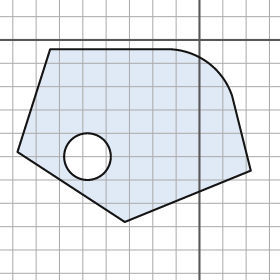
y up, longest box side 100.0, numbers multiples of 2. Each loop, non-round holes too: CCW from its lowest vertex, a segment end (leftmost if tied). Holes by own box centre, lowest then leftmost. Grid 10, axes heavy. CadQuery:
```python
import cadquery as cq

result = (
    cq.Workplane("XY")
    .moveTo(-32.0, -78.0)
    .lineTo(22.0, -56.0)
    .lineTo(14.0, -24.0)
    .threePointArc((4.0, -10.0), (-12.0, -4.0))
    .lineTo(-64.0, -4.0)
    .lineTo(-78.0, -48.0)
    .close()
    .moveTo(-48.0, -50.0)
    .circle(10.0)
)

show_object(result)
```